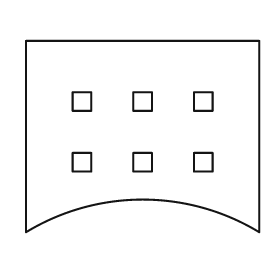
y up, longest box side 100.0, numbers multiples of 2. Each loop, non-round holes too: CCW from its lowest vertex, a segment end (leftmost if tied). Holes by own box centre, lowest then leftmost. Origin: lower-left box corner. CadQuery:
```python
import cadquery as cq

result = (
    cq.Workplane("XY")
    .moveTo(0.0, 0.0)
    .threePointArc((50.0, 14.0), (100.0, 0.0))
    .lineTo(100.0, 82.0)
    .lineTo(0.0, 82.0)
    .close()
    .moveTo(20.0, 26.0)
    .lineTo(28.0, 26.0)
    .lineTo(28.0, 34.0)
    .lineTo(20.0, 34.0)
    .close()
    .moveTo(46.0, 26.0)
    .lineTo(54.0, 26.0)
    .lineTo(54.0, 34.0)
    .lineTo(46.0, 34.0)
    .close()
    .moveTo(72.0, 26.0)
    .lineTo(80.0, 26.0)
    .lineTo(80.0, 34.0)
    .lineTo(72.0, 34.0)
    .close()
    .moveTo(20.0, 52.0)
    .lineTo(28.0, 52.0)
    .lineTo(28.0, 60.0)
    .lineTo(20.0, 60.0)
    .close()
    .moveTo(46.0, 52.0)
    .lineTo(54.0, 52.0)
    .lineTo(54.0, 60.0)
    .lineTo(46.0, 60.0)
    .close()
    .moveTo(72.0, 52.0)
    .lineTo(80.0, 52.0)
    .lineTo(80.0, 60.0)
    .lineTo(72.0, 60.0)
    .close()
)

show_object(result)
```